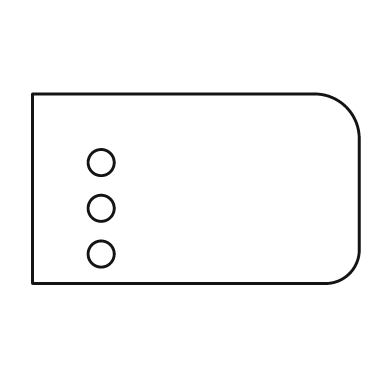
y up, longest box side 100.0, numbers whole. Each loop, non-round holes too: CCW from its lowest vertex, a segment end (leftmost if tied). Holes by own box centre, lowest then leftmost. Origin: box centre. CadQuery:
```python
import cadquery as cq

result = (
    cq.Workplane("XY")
    .moveTo(-50.0, -29.0)
    .lineTo(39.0, -29.0)
    .threePointArc((47.0, -26.0), (50.0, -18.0))
    .lineTo(50.0, 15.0)
    .threePointArc((46.0, 25.0), (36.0, 29.0))
    .lineTo(-50.0, 29.0)
    .close()
    .moveTo(-29.0, -20.0)
    .circle(4.0)
    .moveTo(-29.0, -6.0)
    .circle(4.0)
    .moveTo(-29.0, 8.0)
    .circle(4.0)
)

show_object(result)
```